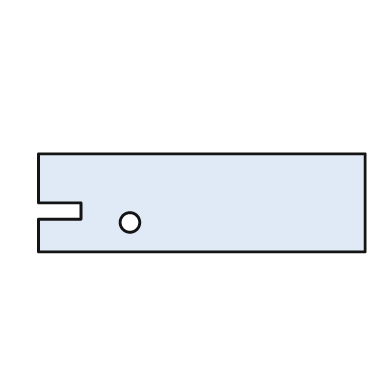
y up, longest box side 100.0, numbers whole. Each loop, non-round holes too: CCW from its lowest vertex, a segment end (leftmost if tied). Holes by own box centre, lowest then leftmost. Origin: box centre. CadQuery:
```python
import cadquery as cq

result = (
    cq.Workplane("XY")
    .moveTo(-50.0, -15.0)
    .lineTo(50.0, -15.0)
    .lineTo(50.0, 15.0)
    .lineTo(-50.0, 15.0)
    .lineTo(-50.0, 0.0)
    .lineTo(-37.0, 0.0)
    .lineTo(-37.0, -5.0)
    .lineTo(-50.0, -5.0)
    .close()
    .moveTo(-22.0, -6.0)
    .circle(3.0)
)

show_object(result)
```